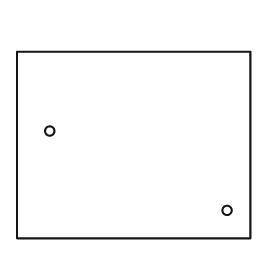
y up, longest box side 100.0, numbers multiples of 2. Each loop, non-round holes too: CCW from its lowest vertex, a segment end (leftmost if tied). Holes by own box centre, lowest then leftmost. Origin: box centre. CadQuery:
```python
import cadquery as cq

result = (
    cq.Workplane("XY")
    .moveTo(-50.0, -40.0)
    .lineTo(50.0, -40.0)
    .lineTo(50.0, 40.0)
    .lineTo(-50.0, 40.0)
    .close()
    .moveTo(40.0, -28.0)
    .circle(2.0)
    .moveTo(-36.0, 6.0)
    .circle(2.0)
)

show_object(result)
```